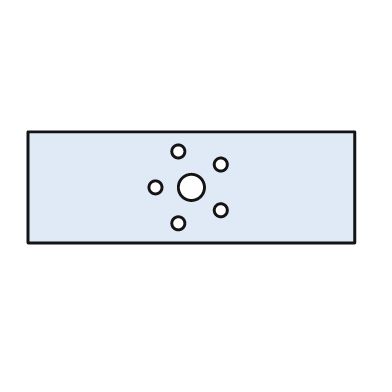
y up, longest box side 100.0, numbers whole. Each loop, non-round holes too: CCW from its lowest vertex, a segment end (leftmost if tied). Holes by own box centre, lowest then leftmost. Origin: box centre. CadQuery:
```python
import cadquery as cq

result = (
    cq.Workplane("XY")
    .moveTo(-50.0, -17.0)
    .lineTo(50.0, -17.0)
    .lineTo(50.0, 17.0)
    .lineTo(-50.0, 17.0)
    .close()
    .moveTo(-4.0, -11.0)
    .circle(2.0)
    .moveTo(9.0, -7.0)
    .circle(2.0)
    .moveTo(-11.0, 0.0)
    .circle(2.0)
    .moveTo(0.0, 0.0)
    .circle(4.0)
    .moveTo(9.0, 7.0)
    .circle(2.0)
    .moveTo(-4.0, 11.0)
    .circle(2.0)
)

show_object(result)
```